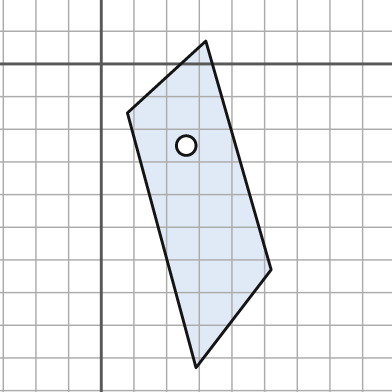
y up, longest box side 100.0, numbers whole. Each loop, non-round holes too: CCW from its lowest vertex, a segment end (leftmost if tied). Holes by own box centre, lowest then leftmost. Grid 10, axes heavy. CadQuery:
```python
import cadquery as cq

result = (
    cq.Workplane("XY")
    .moveTo(29.0, -93.0)
    .lineTo(52.0, -63.0)
    .lineTo(32.0, 7.0)
    .lineTo(8.0, -15.0)
    .close()
    .moveTo(26.0, -25.0)
    .circle(3.0)
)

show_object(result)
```